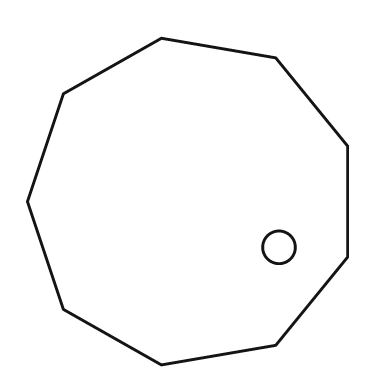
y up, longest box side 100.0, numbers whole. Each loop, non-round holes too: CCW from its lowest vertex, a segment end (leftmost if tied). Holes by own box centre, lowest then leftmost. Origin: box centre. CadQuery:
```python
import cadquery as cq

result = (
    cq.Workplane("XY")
    .moveTo(-8.0, -50.0)
    .lineTo(27.0, -44.0)
    .lineTo(49.0, -17.0)
    .lineTo(49.0, 17.0)
    .lineTo(27.0, 44.0)
    .lineTo(-8.0, 50.0)
    .lineTo(-38.0, 33.0)
    .lineTo(-49.0, 0.0)
    .lineTo(-38.0, -33.0)
    .close()
    .moveTo(28.0, -14.0)
    .circle(5.0)
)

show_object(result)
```